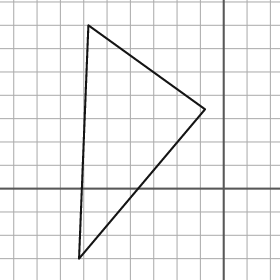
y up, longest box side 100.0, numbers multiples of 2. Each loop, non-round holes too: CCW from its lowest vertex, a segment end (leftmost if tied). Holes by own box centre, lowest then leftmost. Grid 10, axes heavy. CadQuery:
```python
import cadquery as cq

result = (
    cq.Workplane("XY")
    .moveTo(-62.0, -30.0)
    .lineTo(-8.0, 34.0)
    .lineTo(-58.0, 70.0)
    .close()
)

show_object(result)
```